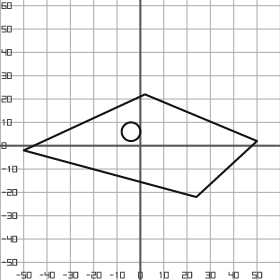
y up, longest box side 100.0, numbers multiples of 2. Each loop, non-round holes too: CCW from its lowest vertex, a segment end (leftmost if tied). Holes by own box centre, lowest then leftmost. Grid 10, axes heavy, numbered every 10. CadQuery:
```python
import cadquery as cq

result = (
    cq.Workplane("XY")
    .moveTo(24.0, -22.0)
    .lineTo(50.0, 2.0)
    .lineTo(2.0, 22.0)
    .lineTo(-50.0, -2.0)
    .close()
    .moveTo(-4.0, 6.0)
    .circle(4.0)
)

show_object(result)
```